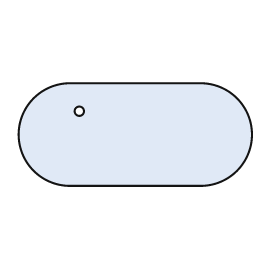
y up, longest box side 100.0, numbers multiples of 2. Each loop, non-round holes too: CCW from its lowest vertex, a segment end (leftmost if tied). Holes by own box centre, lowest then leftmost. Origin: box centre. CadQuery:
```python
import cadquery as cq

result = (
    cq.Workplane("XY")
    .moveTo(-28.0, -22.0)
    .lineTo(28.0, -22.0)
    .threePointArc((50.0, 0.0), (28.0, 22.0))
    .lineTo(-28.0, 22.0)
    .threePointArc((-50.0, 0.0), (-28.0, -22.0))
    .close()
    .moveTo(-24.0, 10.0)
    .circle(2.0)
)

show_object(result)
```